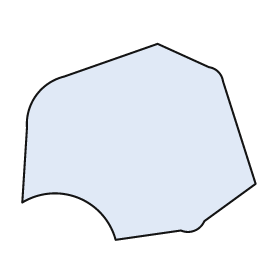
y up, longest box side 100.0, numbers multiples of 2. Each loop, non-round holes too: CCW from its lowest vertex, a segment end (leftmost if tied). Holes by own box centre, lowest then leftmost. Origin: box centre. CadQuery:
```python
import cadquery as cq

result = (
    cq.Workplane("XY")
    .moveTo(-10.0, -42.0)
    .lineTo(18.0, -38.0)
    .threePointArc((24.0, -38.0), (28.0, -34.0))
    .lineTo(50.0, -18.0)
    .lineTo(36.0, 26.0)
    .threePointArc((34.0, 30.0), (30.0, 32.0))
    .lineTo(8.0, 42.0)
    .lineTo(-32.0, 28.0)
    .threePointArc((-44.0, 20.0), (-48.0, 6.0))
    .lineTo(-50.0, -26.0)
    .threePointArc((-26.0, -24.0), (-10.0, -42.0))
    .close()
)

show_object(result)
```